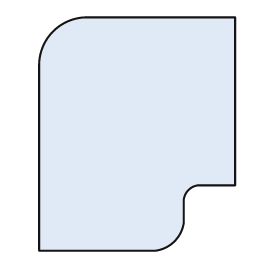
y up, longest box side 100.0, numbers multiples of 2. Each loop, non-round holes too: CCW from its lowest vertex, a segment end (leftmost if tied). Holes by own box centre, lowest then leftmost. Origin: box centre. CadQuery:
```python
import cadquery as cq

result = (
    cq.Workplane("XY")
    .moveTo(-42.0, -50.0)
    .lineTo(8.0, -50.0)
    .threePointArc((16.0, -46.0), (20.0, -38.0))
    .lineTo(20.0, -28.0)
    .threePointArc((22.0, -24.0), (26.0, -22.0))
    .lineTo(42.0, -22.0)
    .lineTo(42.0, 50.0)
    .lineTo(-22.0, 50.0)
    .threePointArc((-36.0, 44.0), (-42.0, 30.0))
    .close()
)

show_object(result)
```